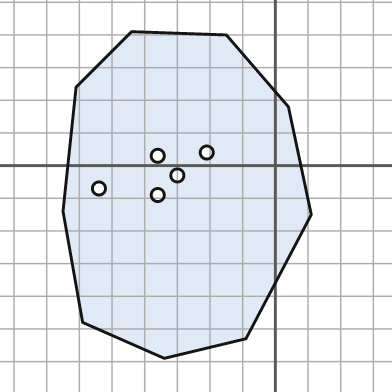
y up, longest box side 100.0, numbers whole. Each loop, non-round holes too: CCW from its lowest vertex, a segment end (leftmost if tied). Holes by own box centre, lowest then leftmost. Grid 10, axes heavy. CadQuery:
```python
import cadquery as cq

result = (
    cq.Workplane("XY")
    .moveTo(-34.0, -59.0)
    .lineTo(-9.0, -53.0)
    .lineTo(11.0, -15.0)
    .lineTo(4.0, 18.0)
    .lineTo(-15.0, 40.0)
    .lineTo(-44.0, 41.0)
    .lineTo(-61.0, 24.0)
    .lineTo(-65.0, -14.0)
    .lineTo(-59.0, -48.0)
    .close()
    .moveTo(-36.0, -9.0)
    .circle(2.0)
    .moveTo(-54.0, -7.0)
    .circle(2.0)
    .moveTo(-30.0, -3.0)
    .circle(2.0)
    .moveTo(-36.0, 3.0)
    .circle(2.0)
    .moveTo(-21.0, 4.0)
    .circle(2.0)
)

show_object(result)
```